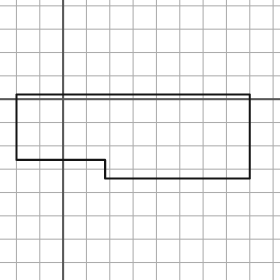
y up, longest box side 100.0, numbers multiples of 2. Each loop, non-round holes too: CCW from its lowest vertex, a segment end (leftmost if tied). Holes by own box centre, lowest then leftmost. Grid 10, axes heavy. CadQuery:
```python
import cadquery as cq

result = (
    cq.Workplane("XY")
    .moveTo(18.0, -34.0)
    .lineTo(80.0, -34.0)
    .lineTo(80.0, 2.0)
    .lineTo(-20.0, 2.0)
    .lineTo(-20.0, -26.0)
    .lineTo(18.0, -26.0)
    .close()
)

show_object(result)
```